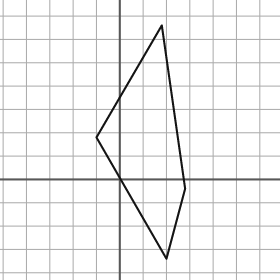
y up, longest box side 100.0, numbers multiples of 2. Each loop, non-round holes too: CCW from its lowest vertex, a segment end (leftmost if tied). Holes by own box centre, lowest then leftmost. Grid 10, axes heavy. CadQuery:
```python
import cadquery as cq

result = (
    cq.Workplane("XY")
    .moveTo(20.0, -34.0)
    .lineTo(28.0, -4.0)
    .lineTo(18.0, 66.0)
    .lineTo(-10.0, 18.0)
    .close()
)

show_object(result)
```